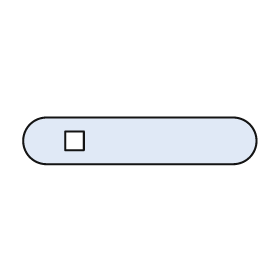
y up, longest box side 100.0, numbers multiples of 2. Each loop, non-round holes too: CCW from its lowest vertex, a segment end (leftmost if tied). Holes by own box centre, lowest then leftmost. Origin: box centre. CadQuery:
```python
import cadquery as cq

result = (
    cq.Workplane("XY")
    .moveTo(-40.0, -10.0)
    .lineTo(40.0, -10.0)
    .threePointArc((50.0, 0.0), (40.0, 10.0))
    .lineTo(-40.0, 10.0)
    .threePointArc((-50.0, 0.0), (-40.0, -10.0))
    .close()
    .moveTo(-32.0, -4.0)
    .lineTo(-24.0, -4.0)
    .lineTo(-24.0, 4.0)
    .lineTo(-32.0, 4.0)
    .close()
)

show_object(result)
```